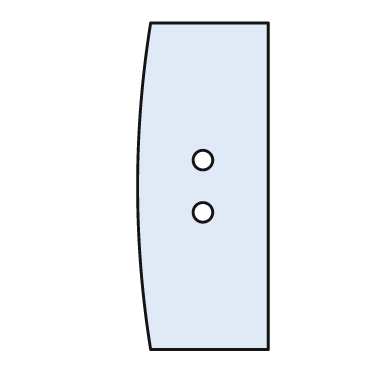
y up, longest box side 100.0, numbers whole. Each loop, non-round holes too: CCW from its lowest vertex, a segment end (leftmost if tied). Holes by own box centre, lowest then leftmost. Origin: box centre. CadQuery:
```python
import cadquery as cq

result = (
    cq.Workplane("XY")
    .moveTo(-16.0, -50.0)
    .lineTo(20.0, -50.0)
    .lineTo(20.0, 50.0)
    .lineTo(-16.0, 50.0)
    .threePointArc((-20.0, 0.0), (-16.0, -50.0))
    .close()
    .moveTo(0.0, -8.0)
    .circle(3.0)
    .moveTo(0.0, 8.0)
    .circle(3.0)
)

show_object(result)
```